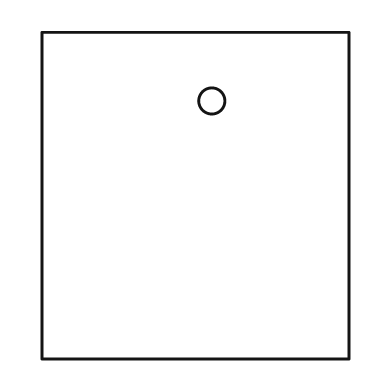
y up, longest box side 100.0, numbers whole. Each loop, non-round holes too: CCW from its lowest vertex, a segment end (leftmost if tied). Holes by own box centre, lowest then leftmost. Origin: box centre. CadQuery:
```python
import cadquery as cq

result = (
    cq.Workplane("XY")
    .moveTo(-47.0, -50.0)
    .lineTo(47.0, -50.0)
    .lineTo(47.0, 50.0)
    .lineTo(-47.0, 50.0)
    .close()
    .moveTo(5.0, 29.0)
    .circle(4.0)
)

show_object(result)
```